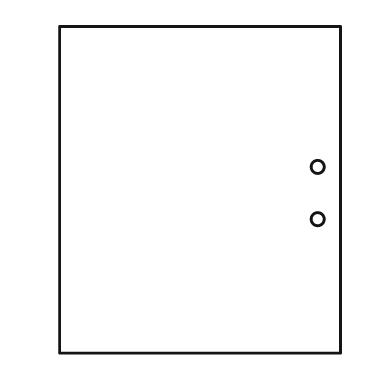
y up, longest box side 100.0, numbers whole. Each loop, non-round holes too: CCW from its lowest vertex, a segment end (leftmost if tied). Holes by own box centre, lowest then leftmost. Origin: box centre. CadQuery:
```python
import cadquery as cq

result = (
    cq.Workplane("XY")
    .moveTo(-43.0, -50.0)
    .lineTo(43.0, -50.0)
    .lineTo(43.0, 50.0)
    .lineTo(-43.0, 50.0)
    .close()
    .moveTo(36.0, -9.0)
    .circle(2.0)
    .moveTo(36.0, 7.0)
    .circle(2.0)
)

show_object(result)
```